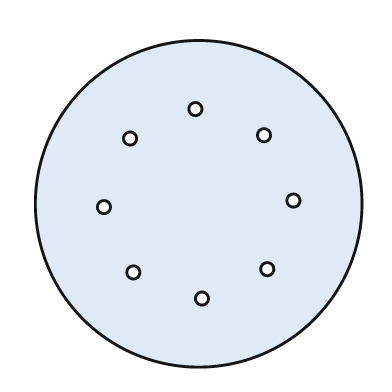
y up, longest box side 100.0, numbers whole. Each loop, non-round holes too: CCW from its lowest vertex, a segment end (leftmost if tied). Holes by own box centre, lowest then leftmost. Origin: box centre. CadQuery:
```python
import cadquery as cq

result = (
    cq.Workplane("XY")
    .moveTo(0.0, 0.0)
    .circle(50.0)
    .moveTo(1.0, -29.0)
    .circle(2.0)
    .moveTo(-20.0, -21.0)
    .circle(2.0)
    .moveTo(21.0, -20.0)
    .circle(2.0)
    .moveTo(-29.0, -1.0)
    .circle(2.0)
    .moveTo(29.0, 1.0)
    .circle(2.0)
    .moveTo(-21.0, 20.0)
    .circle(2.0)
    .moveTo(20.0, 21.0)
    .circle(2.0)
    .moveTo(-1.0, 29.0)
    .circle(2.0)
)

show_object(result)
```